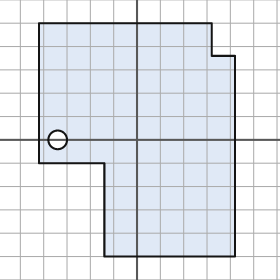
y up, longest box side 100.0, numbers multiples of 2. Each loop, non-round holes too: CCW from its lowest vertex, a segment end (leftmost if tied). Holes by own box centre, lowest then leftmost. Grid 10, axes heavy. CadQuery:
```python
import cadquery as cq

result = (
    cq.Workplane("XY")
    .moveTo(-14.0, -50.0)
    .lineTo(42.0, -50.0)
    .lineTo(42.0, 36.0)
    .lineTo(32.0, 36.0)
    .lineTo(32.0, 50.0)
    .lineTo(-42.0, 50.0)
    .lineTo(-42.0, -10.0)
    .lineTo(-14.0, -10.0)
    .close()
    .moveTo(-34.0, 0.0)
    .circle(4.0)
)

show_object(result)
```